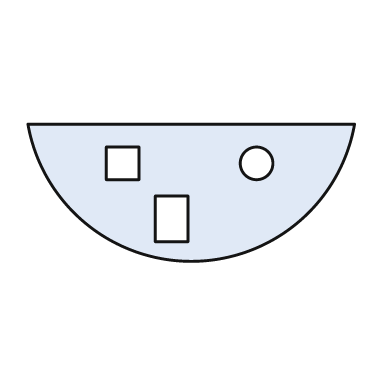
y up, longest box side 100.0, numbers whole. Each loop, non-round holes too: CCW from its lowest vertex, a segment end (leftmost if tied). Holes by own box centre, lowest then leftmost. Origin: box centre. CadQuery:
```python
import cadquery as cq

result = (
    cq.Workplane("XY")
    .moveTo(-50.0, 21.0)
    .threePointArc((0.0, -21.0), (50.0, 21.0))
    .close()
    .moveTo(-11.0, -15.0)
    .lineTo(-1.0, -15.0)
    .lineTo(-1.0, -1.0)
    .lineTo(-11.0, -1.0)
    .close()
    .moveTo(-26.0, 4.0)
    .lineTo(-16.0, 4.0)
    .lineTo(-16.0, 14.0)
    .lineTo(-26.0, 14.0)
    .close()
    .moveTo(20.0, 9.0)
    .circle(5.0)
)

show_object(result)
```